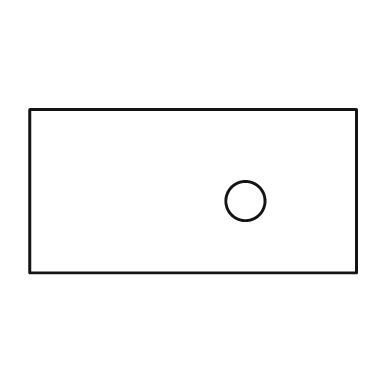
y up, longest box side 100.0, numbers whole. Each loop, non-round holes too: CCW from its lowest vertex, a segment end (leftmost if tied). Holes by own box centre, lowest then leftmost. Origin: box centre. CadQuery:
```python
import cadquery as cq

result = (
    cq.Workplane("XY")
    .moveTo(-50.0, -25.0)
    .lineTo(50.0, -25.0)
    .lineTo(50.0, 25.0)
    .lineTo(-50.0, 25.0)
    .close()
    .moveTo(16.0, -3.0)
    .circle(6.0)
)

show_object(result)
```